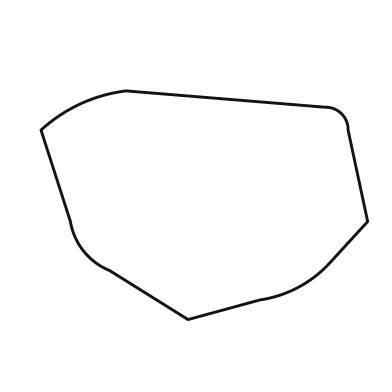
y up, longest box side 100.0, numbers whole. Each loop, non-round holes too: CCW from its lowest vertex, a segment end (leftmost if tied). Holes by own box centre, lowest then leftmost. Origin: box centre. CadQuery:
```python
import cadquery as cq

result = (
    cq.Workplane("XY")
    .moveTo(-5.0, -35.0)
    .lineTo(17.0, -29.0)
    .threePointArc((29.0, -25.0), (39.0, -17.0))
    .lineTo(50.0, -5.0)
    .lineTo(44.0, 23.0)
    .threePointArc((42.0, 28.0), (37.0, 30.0))
    .lineTo(-24.0, 35.0)
    .threePointArc((-38.0, 31.0), (-50.0, 23.0))
    .lineTo(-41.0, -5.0)
    .threePointArc((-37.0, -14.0), (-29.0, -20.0))
    .close()
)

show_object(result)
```